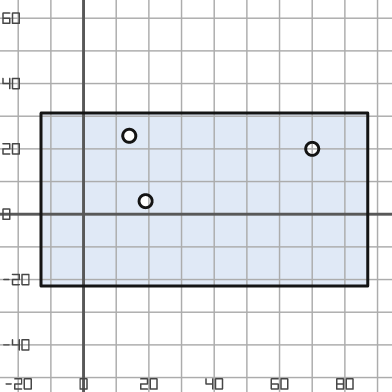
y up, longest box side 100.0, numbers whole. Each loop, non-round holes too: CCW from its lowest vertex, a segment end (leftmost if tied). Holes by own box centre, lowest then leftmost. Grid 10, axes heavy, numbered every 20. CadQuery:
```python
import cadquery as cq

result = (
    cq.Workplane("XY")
    .moveTo(-13.0, -22.0)
    .lineTo(87.0, -22.0)
    .lineTo(87.0, 31.0)
    .lineTo(-13.0, 31.0)
    .close()
    .moveTo(19.0, 4.0)
    .circle(2.0)
    .moveTo(70.0, 20.0)
    .circle(2.0)
    .moveTo(14.0, 24.0)
    .circle(2.0)
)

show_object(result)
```